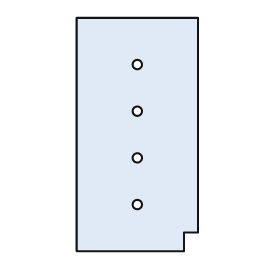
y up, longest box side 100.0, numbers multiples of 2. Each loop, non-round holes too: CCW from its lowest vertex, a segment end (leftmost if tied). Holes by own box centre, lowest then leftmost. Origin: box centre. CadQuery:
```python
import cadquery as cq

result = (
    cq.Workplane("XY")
    .moveTo(-26.0, -50.0)
    .lineTo(20.0, -50.0)
    .lineTo(20.0, -42.0)
    .lineTo(26.0, -42.0)
    .lineTo(26.0, 50.0)
    .lineTo(-26.0, 50.0)
    .close()
    .moveTo(0.0, -30.0)
    .circle(2.0)
    .moveTo(0.0, -10.0)
    .circle(2.0)
    .moveTo(0.0, 10.0)
    .circle(2.0)
    .moveTo(0.0, 30.0)
    .circle(2.0)
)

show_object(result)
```